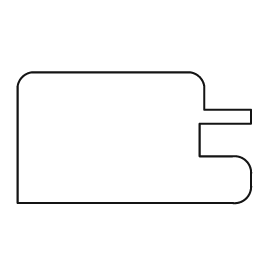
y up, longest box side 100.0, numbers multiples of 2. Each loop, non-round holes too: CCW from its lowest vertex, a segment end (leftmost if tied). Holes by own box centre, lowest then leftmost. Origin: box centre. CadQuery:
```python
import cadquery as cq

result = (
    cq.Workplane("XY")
    .moveTo(-50.0, -28.0)
    .lineTo(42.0, -28.0)
    .threePointArc((48.0, -26.0), (50.0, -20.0))
    .lineTo(50.0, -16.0)
    .threePointArc((48.0, -10.0), (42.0, -8.0))
    .lineTo(28.0, -8.0)
    .lineTo(28.0, 6.0)
    .lineTo(50.0, 6.0)
    .lineTo(50.0, 12.0)
    .lineTo(30.0, 12.0)
    .lineTo(30.0, 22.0)
    .threePointArc((28.0, 26.0), (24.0, 28.0))
    .lineTo(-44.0, 28.0)
    .threePointArc((-48.0, 26.0), (-50.0, 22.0))
    .close()
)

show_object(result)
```